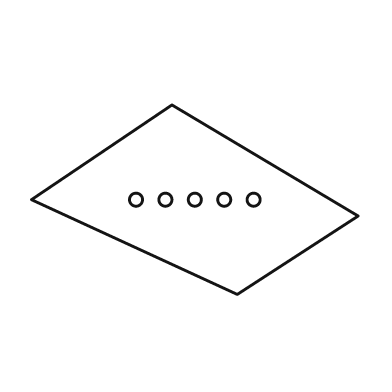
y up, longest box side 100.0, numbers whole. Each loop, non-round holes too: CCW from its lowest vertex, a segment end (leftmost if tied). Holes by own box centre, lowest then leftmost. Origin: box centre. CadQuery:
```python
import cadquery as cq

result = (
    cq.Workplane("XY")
    .moveTo(13.0, -29.0)
    .lineTo(50.0, -5.0)
    .lineTo(-7.0, 29.0)
    .lineTo(-50.0, 0.0)
    .close()
    .moveTo(-18.0, 0.0)
    .circle(2.0)
    .moveTo(-9.0, 0.0)
    .circle(2.0)
    .moveTo(0.0, 0.0)
    .circle(2.0)
    .moveTo(9.0, 0.0)
    .circle(2.0)
    .moveTo(18.0, 0.0)
    .circle(2.0)
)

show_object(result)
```